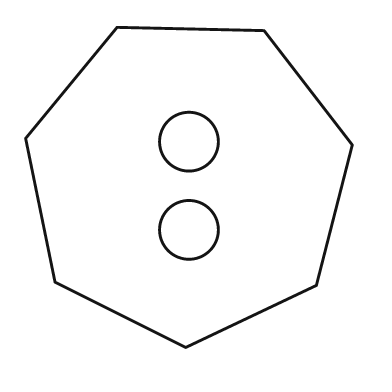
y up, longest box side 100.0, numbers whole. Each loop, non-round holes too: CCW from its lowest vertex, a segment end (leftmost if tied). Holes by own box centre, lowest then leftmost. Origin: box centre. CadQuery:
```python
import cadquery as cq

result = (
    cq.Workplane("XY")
    .moveTo(-1.0, -49.0)
    .lineTo(39.0, -30.0)
    .lineTo(50.0, 13.0)
    .lineTo(23.0, 48.0)
    .lineTo(-22.0, 49.0)
    .lineTo(-50.0, 15.0)
    .lineTo(-41.0, -29.0)
    .close()
    .moveTo(0.0, -13.0)
    .circle(9.0)
    .moveTo(0.0, 14.0)
    .circle(9.0)
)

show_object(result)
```